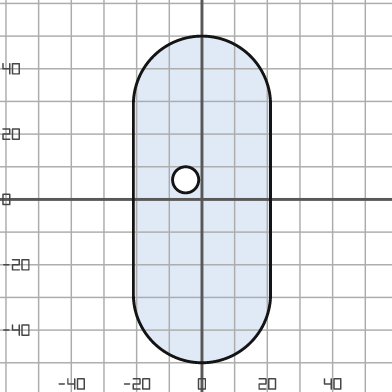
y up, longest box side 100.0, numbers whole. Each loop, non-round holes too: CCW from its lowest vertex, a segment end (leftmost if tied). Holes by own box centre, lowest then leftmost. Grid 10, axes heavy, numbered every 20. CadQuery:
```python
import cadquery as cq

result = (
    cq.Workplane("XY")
    .moveTo(-21.0, -29.0)
    .threePointArc((0.0, -50.0), (21.0, -29.0))
    .lineTo(21.0, 29.0)
    .threePointArc((0.0, 50.0), (-21.0, 29.0))
    .close()
    .moveTo(-5.0, 6.0)
    .circle(4.0)
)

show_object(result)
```